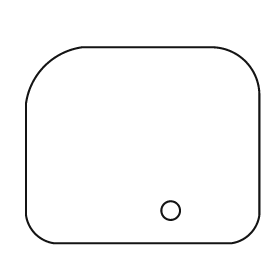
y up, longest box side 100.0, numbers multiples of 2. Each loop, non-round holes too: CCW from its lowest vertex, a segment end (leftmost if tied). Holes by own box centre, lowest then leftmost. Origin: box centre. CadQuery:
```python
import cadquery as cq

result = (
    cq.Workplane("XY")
    .moveTo(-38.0, -42.0)
    .lineTo(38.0, -42.0)
    .threePointArc((46.0, -38.0), (50.0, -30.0))
    .lineTo(50.0, 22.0)
    .threePointArc((44.0, 36.0), (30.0, 42.0))
    .lineTo(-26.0, 42.0)
    .threePointArc((-42.0, 34.0), (-50.0, 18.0))
    .lineTo(-50.0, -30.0)
    .threePointArc((-46.0, -38.0), (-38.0, -42.0))
    .close()
    .moveTo(12.0, -28.0)
    .circle(4.0)
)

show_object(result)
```